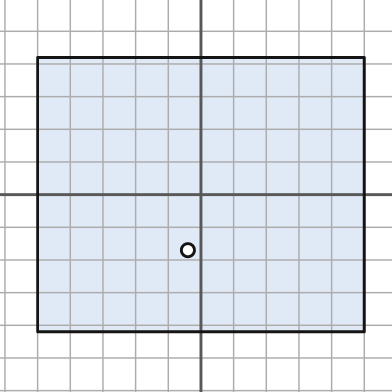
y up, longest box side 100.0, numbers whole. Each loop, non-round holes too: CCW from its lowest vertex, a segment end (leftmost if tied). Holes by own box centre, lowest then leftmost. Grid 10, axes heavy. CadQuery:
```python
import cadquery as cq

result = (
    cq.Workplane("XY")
    .moveTo(-50.0, -42.0)
    .lineTo(50.0, -42.0)
    .lineTo(50.0, 42.0)
    .lineTo(-50.0, 42.0)
    .close()
    .moveTo(-4.0, -17.0)
    .circle(2.0)
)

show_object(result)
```